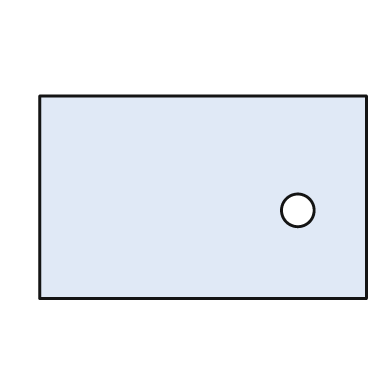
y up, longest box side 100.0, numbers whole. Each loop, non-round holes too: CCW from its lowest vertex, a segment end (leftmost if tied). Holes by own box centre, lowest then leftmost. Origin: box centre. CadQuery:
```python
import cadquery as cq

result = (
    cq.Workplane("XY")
    .moveTo(-50.0, -31.0)
    .lineTo(50.0, -31.0)
    .lineTo(50.0, 31.0)
    .lineTo(-50.0, 31.0)
    .close()
    .moveTo(29.0, -4.0)
    .circle(5.0)
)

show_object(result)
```